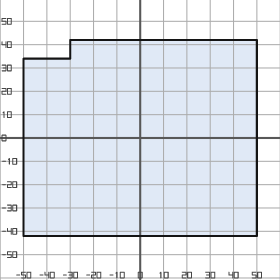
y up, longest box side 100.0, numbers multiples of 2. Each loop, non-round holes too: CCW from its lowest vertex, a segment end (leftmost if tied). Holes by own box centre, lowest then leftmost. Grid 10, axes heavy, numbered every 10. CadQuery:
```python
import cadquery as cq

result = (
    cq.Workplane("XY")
    .moveTo(-50.0, -42.0)
    .lineTo(50.0, -42.0)
    .lineTo(50.0, 42.0)
    .lineTo(-30.0, 42.0)
    .lineTo(-30.0, 34.0)
    .lineTo(-50.0, 34.0)
    .close()
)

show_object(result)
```